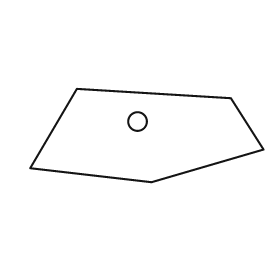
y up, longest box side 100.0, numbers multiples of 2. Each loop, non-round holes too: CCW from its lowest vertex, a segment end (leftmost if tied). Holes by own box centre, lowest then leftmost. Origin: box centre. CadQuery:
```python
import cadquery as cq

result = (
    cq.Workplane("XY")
    .moveTo(2.0, -20.0)
    .lineTo(50.0, -6.0)
    .lineTo(36.0, 16.0)
    .lineTo(-30.0, 20.0)
    .lineTo(-50.0, -14.0)
    .close()
    .moveTo(-4.0, 6.0)
    .circle(4.0)
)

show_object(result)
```